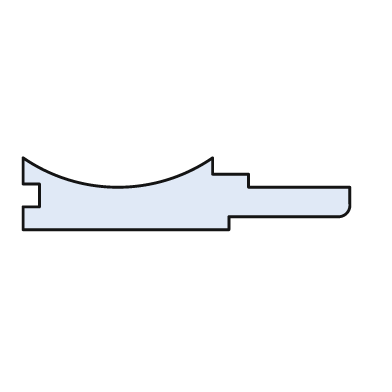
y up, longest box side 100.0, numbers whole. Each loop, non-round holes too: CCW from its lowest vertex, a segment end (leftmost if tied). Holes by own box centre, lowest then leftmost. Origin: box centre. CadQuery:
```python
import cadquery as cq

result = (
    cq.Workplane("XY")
    .moveTo(-50.0, -11.0)
    .lineTo(13.0, -11.0)
    .lineTo(13.0, -7.0)
    .lineTo(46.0, -7.0)
    .threePointArc((49.0, -6.0), (50.0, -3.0))
    .lineTo(50.0, 2.0)
    .lineTo(19.0, 2.0)
    .lineTo(19.0, 6.0)
    .lineTo(8.0, 6.0)
    .lineTo(8.0, 11.0)
    .threePointArc((-21.0, 2.0), (-50.0, 11.0))
    .lineTo(-50.0, 3.0)
    .lineTo(-45.0, 3.0)
    .lineTo(-45.0, -4.0)
    .lineTo(-50.0, -4.0)
    .close()
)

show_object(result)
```